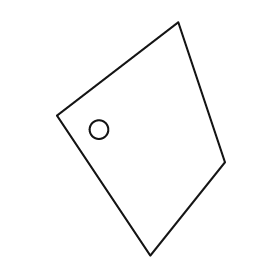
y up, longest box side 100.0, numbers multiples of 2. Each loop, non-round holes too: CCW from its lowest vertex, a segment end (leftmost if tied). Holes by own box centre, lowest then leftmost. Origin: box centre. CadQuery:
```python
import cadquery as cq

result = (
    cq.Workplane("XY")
    .moveTo(4.0, -50.0)
    .lineTo(36.0, -10.0)
    .lineTo(16.0, 50.0)
    .lineTo(-36.0, 10.0)
    .close()
    .moveTo(-18.0, 4.0)
    .circle(4.0)
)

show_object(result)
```